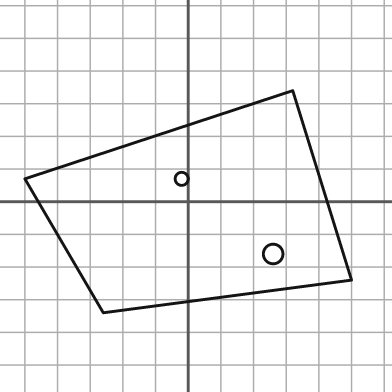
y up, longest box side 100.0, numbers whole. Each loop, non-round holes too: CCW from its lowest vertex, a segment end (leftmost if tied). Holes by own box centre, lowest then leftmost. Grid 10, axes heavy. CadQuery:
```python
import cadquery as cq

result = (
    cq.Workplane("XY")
    .moveTo(-26.0, -34.0)
    .lineTo(50.0, -24.0)
    .lineTo(32.0, 34.0)
    .lineTo(-50.0, 7.0)
    .close()
    .moveTo(26.0, -16.0)
    .circle(3.0)
    .moveTo(-2.0, 7.0)
    .circle(2.0)
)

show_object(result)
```